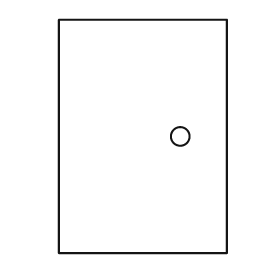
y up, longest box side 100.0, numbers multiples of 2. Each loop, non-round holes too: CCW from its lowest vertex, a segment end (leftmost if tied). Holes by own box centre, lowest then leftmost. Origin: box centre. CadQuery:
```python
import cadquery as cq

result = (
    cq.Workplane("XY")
    .moveTo(-36.0, -50.0)
    .lineTo(36.0, -50.0)
    .lineTo(36.0, 50.0)
    .lineTo(-36.0, 50.0)
    .close()
    .moveTo(16.0, 0.0)
    .circle(4.0)
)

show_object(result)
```